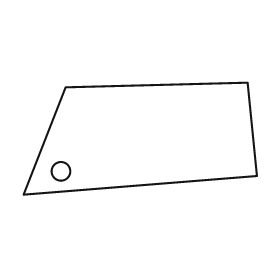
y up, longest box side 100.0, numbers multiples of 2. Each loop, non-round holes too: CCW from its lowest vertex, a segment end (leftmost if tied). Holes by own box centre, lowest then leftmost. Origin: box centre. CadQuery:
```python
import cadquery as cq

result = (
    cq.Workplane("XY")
    .moveTo(-50.0, -24.0)
    .lineTo(50.0, -16.0)
    .lineTo(46.0, 24.0)
    .lineTo(-32.0, 22.0)
    .close()
    .moveTo(-34.0, -14.0)
    .circle(4.0)
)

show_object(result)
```